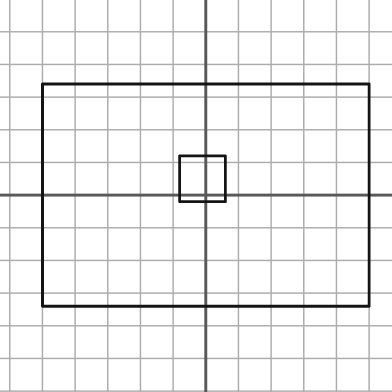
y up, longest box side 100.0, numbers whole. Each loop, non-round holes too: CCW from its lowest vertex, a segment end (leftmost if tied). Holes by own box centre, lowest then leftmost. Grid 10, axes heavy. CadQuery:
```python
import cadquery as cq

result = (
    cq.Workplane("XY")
    .moveTo(-50.0, -34.0)
    .lineTo(50.0, -34.0)
    .lineTo(50.0, 34.0)
    .lineTo(-50.0, 34.0)
    .close()
    .moveTo(-8.0, -2.0)
    .lineTo(6.0, -2.0)
    .lineTo(6.0, 12.0)
    .lineTo(-8.0, 12.0)
    .close()
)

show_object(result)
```